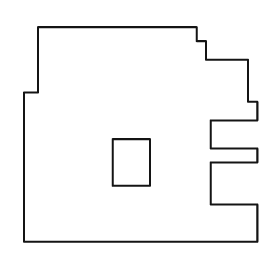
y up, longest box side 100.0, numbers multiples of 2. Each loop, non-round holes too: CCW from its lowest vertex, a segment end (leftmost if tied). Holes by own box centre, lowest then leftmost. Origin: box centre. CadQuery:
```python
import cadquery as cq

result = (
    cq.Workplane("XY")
    .moveTo(-50.0, -46.0)
    .lineTo(50.0, -46.0)
    .lineTo(50.0, -30.0)
    .lineTo(30.0, -30.0)
    .lineTo(30.0, -12.0)
    .lineTo(50.0, -12.0)
    .lineTo(50.0, -6.0)
    .lineTo(30.0, -6.0)
    .lineTo(30.0, 6.0)
    .lineTo(50.0, 6.0)
    .lineTo(50.0, 14.0)
    .lineTo(46.0, 14.0)
    .lineTo(46.0, 32.0)
    .lineTo(28.0, 32.0)
    .lineTo(28.0, 40.0)
    .lineTo(24.0, 40.0)
    .lineTo(24.0, 46.0)
    .lineTo(-44.0, 46.0)
    .lineTo(-44.0, 18.0)
    .lineTo(-50.0, 18.0)
    .close()
    .moveTo(-12.0, -22.0)
    .lineTo(4.0, -22.0)
    .lineTo(4.0, -2.0)
    .lineTo(-12.0, -2.0)
    .close()
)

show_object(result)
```